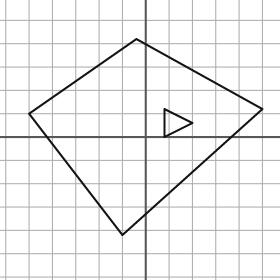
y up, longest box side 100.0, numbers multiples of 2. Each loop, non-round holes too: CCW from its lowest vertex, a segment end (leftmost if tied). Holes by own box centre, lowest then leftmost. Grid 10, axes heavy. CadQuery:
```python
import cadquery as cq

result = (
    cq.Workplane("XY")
    .moveTo(-10.0, -42.0)
    .lineTo(50.0, 12.0)
    .lineTo(-4.0, 42.0)
    .lineTo(-50.0, 10.0)
    .close()
    .moveTo(8.0, 0.0)
    .lineTo(20.0, 6.0)
    .lineTo(8.0, 12.0)
    .close()
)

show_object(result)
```